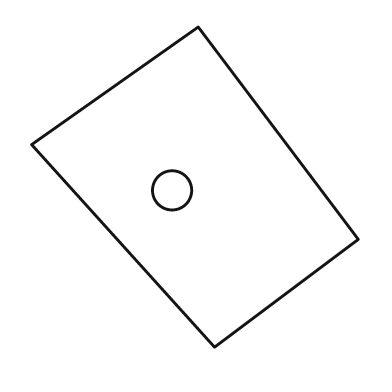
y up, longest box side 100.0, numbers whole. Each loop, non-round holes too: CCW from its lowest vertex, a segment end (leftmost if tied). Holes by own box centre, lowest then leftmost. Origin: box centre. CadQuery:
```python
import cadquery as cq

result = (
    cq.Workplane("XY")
    .moveTo(6.0, -49.0)
    .lineTo(50.0, -16.0)
    .lineTo(1.0, 49.0)
    .lineTo(-50.0, 13.0)
    .close()
    .moveTo(-7.0, -1.0)
    .circle(6.0)
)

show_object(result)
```